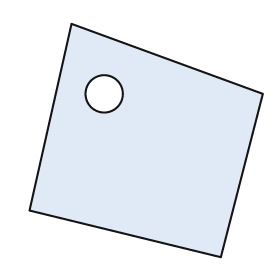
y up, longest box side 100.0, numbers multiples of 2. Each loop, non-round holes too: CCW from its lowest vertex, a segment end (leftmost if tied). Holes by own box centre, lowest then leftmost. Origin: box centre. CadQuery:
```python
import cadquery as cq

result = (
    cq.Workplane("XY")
    .moveTo(32.0, -50.0)
    .lineTo(50.0, 20.0)
    .lineTo(-32.0, 50.0)
    .lineTo(-50.0, -30.0)
    .close()
    .moveTo(-18.0, 20.0)
    .circle(8.0)
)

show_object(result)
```